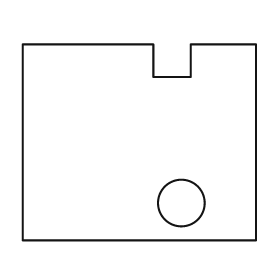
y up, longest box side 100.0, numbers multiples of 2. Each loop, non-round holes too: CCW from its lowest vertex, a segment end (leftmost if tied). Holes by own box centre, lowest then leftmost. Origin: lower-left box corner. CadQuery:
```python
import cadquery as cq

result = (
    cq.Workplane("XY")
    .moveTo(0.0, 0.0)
    .lineTo(100.0, 0.0)
    .lineTo(100.0, 84.0)
    .lineTo(72.0, 84.0)
    .lineTo(72.0, 70.0)
    .lineTo(56.0, 70.0)
    .lineTo(56.0, 84.0)
    .lineTo(0.0, 84.0)
    .close()
    .moveTo(68.0, 16.0)
    .circle(10.0)
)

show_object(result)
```